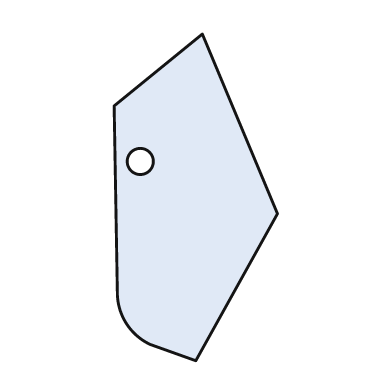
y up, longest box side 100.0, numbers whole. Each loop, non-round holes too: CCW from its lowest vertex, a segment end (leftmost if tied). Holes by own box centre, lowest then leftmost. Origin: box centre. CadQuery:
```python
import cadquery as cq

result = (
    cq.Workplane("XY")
    .moveTo(0.0, -50.0)
    .lineTo(25.0, -5.0)
    .lineTo(2.0, 50.0)
    .lineTo(-25.0, 28.0)
    .lineTo(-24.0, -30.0)
    .threePointArc((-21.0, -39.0), (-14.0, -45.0))
    .close()
    .moveTo(-17.0, 11.0)
    .circle(4.0)
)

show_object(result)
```